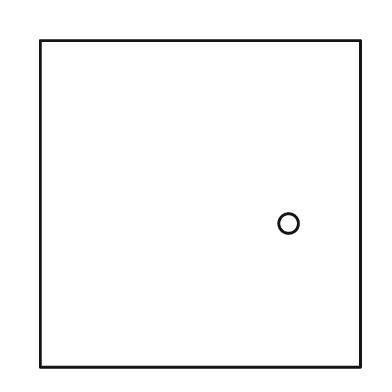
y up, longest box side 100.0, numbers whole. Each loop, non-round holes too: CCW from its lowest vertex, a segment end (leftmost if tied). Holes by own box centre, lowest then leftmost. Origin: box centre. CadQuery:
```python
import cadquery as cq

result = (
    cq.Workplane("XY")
    .moveTo(-49.0, -50.0)
    .lineTo(49.0, -50.0)
    .lineTo(49.0, 50.0)
    .lineTo(-49.0, 50.0)
    .close()
    .moveTo(27.0, -6.0)
    .circle(3.0)
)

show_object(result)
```